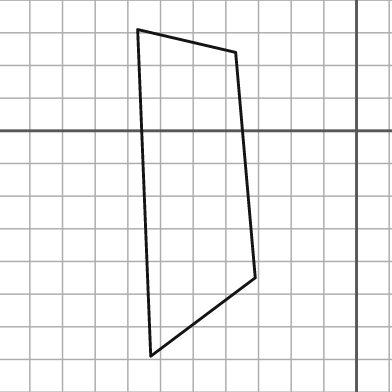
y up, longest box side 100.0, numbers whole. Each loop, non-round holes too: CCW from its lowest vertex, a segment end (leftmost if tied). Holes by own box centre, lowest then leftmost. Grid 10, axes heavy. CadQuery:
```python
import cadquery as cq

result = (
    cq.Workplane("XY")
    .moveTo(-63.0, -69.0)
    .lineTo(-31.0, -45.0)
    .lineTo(-37.0, 24.0)
    .lineTo(-67.0, 31.0)
    .close()
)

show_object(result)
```